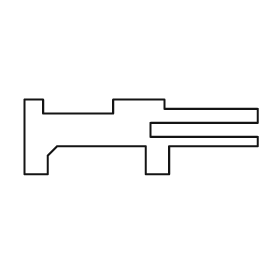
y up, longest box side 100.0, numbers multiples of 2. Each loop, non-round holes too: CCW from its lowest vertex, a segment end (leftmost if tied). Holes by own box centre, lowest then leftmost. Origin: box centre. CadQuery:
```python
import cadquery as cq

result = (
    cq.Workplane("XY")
    .moveTo(-50.0, -16.0)
    .lineTo(-40.0, -16.0)
    .lineTo(-40.0, -8.0)
    .lineTo(-36.0, -4.0)
    .lineTo(2.0, -4.0)
    .lineTo(2.0, -16.0)
    .lineTo(12.0, -16.0)
    .lineTo(12.0, -4.0)
    .lineTo(50.0, -4.0)
    .lineTo(50.0, 0.0)
    .lineTo(4.0, 0.0)
    .lineTo(4.0, 6.0)
    .lineTo(50.0, 6.0)
    .lineTo(50.0, 12.0)
    .lineTo(10.0, 12.0)
    .lineTo(10.0, 16.0)
    .lineTo(-12.0, 16.0)
    .lineTo(-12.0, 10.0)
    .lineTo(-42.0, 10.0)
    .lineTo(-42.0, 16.0)
    .lineTo(-50.0, 16.0)
    .close()
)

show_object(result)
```